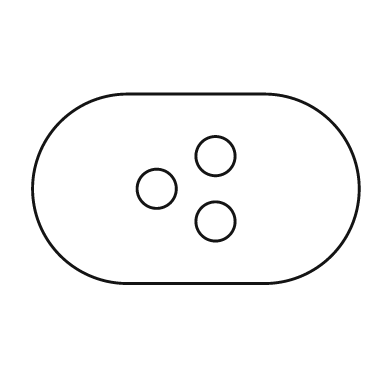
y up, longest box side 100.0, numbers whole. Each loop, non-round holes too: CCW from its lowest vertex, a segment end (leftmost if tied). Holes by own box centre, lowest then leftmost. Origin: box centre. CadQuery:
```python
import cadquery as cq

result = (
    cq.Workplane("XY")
    .moveTo(-21.0, -29.0)
    .lineTo(21.0, -29.0)
    .threePointArc((50.0, 0.0), (21.0, 29.0))
    .lineTo(-21.0, 29.0)
    .threePointArc((-50.0, 0.0), (-21.0, -29.0))
    .close()
    .moveTo(6.0, -10.0)
    .circle(6.0)
    .moveTo(-12.0, 0.0)
    .circle(6.0)
    .moveTo(6.0, 10.0)
    .circle(6.0)
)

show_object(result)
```